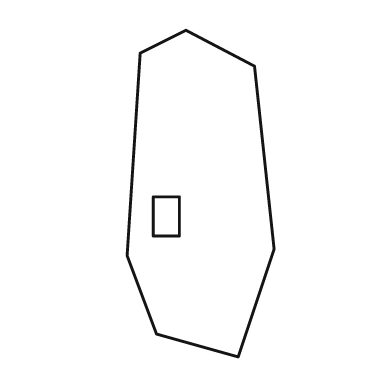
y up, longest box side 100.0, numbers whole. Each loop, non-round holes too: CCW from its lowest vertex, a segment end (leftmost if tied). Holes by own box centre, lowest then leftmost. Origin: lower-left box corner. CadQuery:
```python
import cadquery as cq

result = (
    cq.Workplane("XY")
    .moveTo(34.0, 0.0)
    .lineTo(45.0, 33.0)
    .lineTo(39.0, 89.0)
    .lineTo(18.0, 100.0)
    .lineTo(4.0, 93.0)
    .lineTo(0.0, 31.0)
    .lineTo(9.0, 7.0)
    .close()
    .moveTo(8.0, 37.0)
    .lineTo(16.0, 37.0)
    .lineTo(16.0, 49.0)
    .lineTo(8.0, 49.0)
    .close()
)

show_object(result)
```